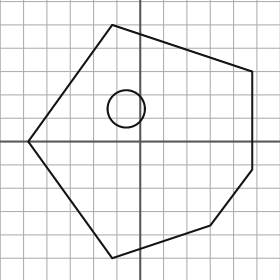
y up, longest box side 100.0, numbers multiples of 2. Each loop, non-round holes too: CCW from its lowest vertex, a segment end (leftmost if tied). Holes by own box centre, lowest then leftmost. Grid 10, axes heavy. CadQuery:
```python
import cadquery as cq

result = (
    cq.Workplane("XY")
    .moveTo(-12.0, -50.0)
    .lineTo(30.0, -36.0)
    .lineTo(48.0, -12.0)
    .lineTo(48.0, 30.0)
    .lineTo(-12.0, 50.0)
    .lineTo(-48.0, 0.0)
    .close()
    .moveTo(-6.0, 14.0)
    .circle(8.0)
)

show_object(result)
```